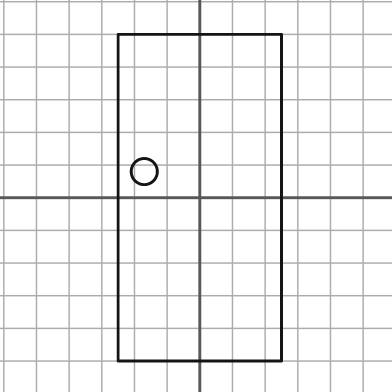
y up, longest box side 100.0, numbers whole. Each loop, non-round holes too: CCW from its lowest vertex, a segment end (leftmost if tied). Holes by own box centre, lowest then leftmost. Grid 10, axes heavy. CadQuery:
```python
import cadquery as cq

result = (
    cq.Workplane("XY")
    .moveTo(-25.0, -50.0)
    .lineTo(25.0, -50.0)
    .lineTo(25.0, 50.0)
    .lineTo(-25.0, 50.0)
    .close()
    .moveTo(-17.0, 8.0)
    .circle(4.0)
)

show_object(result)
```